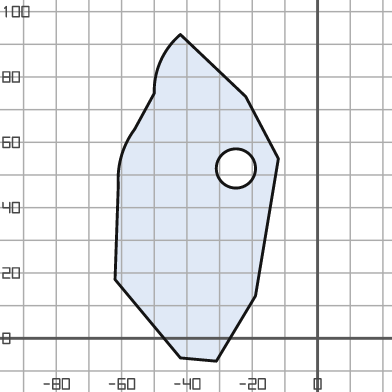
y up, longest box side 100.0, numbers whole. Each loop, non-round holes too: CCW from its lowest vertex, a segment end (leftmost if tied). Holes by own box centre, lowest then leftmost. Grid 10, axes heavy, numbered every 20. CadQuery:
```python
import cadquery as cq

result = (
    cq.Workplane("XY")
    .moveTo(-31.0, -7.0)
    .lineTo(-19.0, 13.0)
    .lineTo(-12.0, 55.0)
    .lineTo(-22.0, 74.0)
    .lineTo(-42.0, 93.0)
    .threePointArc((-48.0, 85.0), (-50.0, 75.0))
    .lineTo(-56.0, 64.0)
    .threePointArc((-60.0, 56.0), (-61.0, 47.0))
    .lineTo(-62.0, 18.0)
    .lineTo(-42.0, -6.0)
    .close()
    .moveTo(-25.0, 52.0)
    .circle(6.0)
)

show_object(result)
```